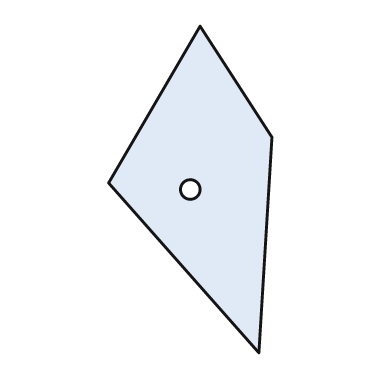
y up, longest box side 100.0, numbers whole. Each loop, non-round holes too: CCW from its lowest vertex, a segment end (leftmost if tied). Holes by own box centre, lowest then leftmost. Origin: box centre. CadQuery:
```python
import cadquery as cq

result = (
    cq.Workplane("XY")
    .moveTo(21.0, -50.0)
    .lineTo(25.0, 16.0)
    .lineTo(3.0, 50.0)
    .lineTo(-25.0, 2.0)
    .close()
    .moveTo(0.0, 0.0)
    .circle(3.0)
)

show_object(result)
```